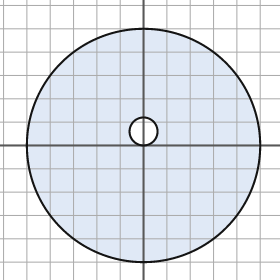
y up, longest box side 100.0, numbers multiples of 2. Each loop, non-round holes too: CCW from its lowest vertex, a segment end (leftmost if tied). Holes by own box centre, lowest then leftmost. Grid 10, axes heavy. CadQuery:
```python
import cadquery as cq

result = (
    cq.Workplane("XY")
    .moveTo(0.0, 0.0)
    .circle(50.0)
    .moveTo(0.0, 6.0)
    .circle(6.0)
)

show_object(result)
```